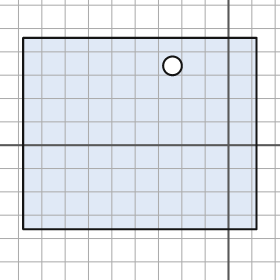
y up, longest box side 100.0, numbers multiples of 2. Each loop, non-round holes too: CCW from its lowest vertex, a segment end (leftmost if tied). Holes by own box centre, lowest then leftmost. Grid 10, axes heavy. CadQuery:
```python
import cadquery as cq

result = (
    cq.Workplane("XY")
    .moveTo(-88.0, -36.0)
    .lineTo(12.0, -36.0)
    .lineTo(12.0, 46.0)
    .lineTo(-88.0, 46.0)
    .close()
    .moveTo(-24.0, 34.0)
    .circle(4.0)
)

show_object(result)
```